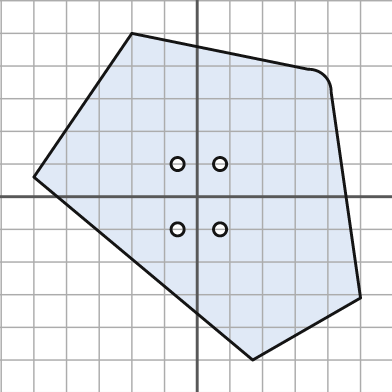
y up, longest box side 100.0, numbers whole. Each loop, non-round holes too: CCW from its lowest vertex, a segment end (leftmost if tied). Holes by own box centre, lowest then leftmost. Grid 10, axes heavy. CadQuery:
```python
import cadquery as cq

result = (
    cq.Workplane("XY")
    .moveTo(17.0, -50.0)
    .lineTo(50.0, -31.0)
    .lineTo(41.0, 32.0)
    .threePointArc((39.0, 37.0), (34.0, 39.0))
    .lineTo(-20.0, 50.0)
    .lineTo(-50.0, 6.0)
    .close()
    .moveTo(-6.0, -10.0)
    .circle(2.0)
    .moveTo(7.0, -10.0)
    .circle(2.0)
    .moveTo(-6.0, 10.0)
    .circle(2.0)
    .moveTo(7.0, 10.0)
    .circle(2.0)
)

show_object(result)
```